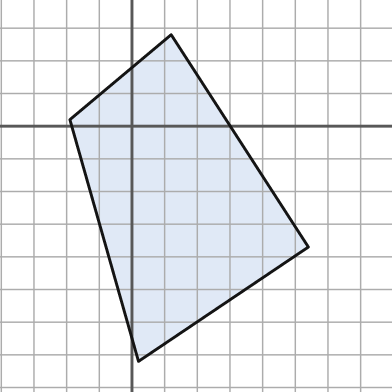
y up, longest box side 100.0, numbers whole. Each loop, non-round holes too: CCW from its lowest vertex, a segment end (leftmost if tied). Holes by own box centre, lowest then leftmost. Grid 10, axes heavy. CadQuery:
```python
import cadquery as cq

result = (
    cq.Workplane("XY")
    .moveTo(2.0, -72.0)
    .lineTo(54.0, -37.0)
    .lineTo(12.0, 28.0)
    .lineTo(-19.0, 2.0)
    .close()
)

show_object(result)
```